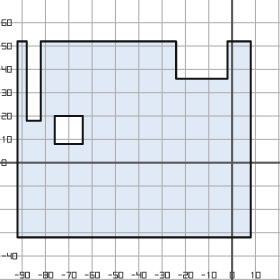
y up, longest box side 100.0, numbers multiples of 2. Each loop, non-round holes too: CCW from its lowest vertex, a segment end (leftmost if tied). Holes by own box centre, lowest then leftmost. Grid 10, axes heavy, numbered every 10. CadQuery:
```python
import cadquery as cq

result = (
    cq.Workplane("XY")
    .moveTo(-92.0, -32.0)
    .lineTo(8.0, -32.0)
    .lineTo(8.0, 52.0)
    .lineTo(-2.0, 52.0)
    .lineTo(-2.0, 36.0)
    .lineTo(-24.0, 36.0)
    .lineTo(-24.0, 52.0)
    .lineTo(-82.0, 52.0)
    .lineTo(-82.0, 18.0)
    .lineTo(-88.0, 18.0)
    .lineTo(-88.0, 52.0)
    .lineTo(-92.0, 52.0)
    .close()
    .moveTo(-76.0, 8.0)
    .lineTo(-64.0, 8.0)
    .lineTo(-64.0, 20.0)
    .lineTo(-76.0, 20.0)
    .close()
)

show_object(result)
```